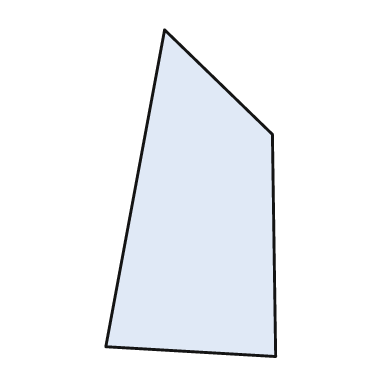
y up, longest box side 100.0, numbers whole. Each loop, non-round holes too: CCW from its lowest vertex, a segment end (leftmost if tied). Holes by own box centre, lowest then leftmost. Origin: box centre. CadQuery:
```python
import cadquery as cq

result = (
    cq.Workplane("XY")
    .moveTo(26.0, -50.0)
    .lineTo(25.0, 18.0)
    .lineTo(-8.0, 50.0)
    .lineTo(-26.0, -47.0)
    .close()
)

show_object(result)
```